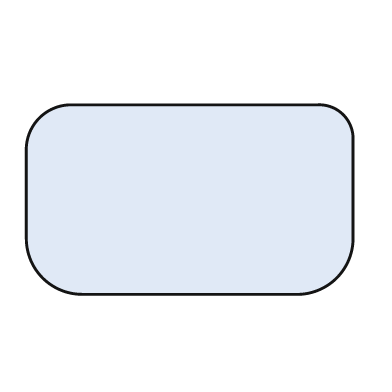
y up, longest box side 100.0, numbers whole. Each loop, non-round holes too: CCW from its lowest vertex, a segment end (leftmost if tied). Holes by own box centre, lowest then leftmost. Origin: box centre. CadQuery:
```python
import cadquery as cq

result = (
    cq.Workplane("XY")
    .moveTo(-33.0, -29.0)
    .lineTo(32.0, -29.0)
    .threePointArc((45.0, -24.0), (50.0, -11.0))
    .lineTo(50.0, 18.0)
    .threePointArc((47.0, 26.0), (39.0, 29.0))
    .lineTo(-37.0, 29.0)
    .threePointArc((-46.0, 25.0), (-50.0, 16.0))
    .lineTo(-50.0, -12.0)
    .threePointArc((-45.0, -24.0), (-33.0, -29.0))
    .close()
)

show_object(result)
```